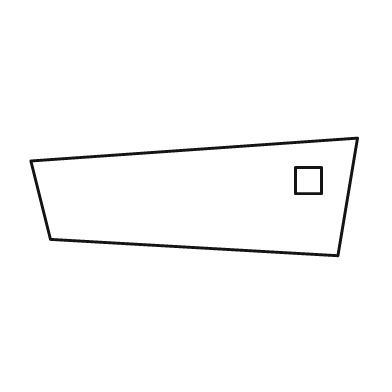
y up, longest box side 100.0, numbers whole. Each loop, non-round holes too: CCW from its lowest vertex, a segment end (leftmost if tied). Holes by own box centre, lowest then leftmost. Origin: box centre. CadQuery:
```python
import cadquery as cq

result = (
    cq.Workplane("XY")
    .moveTo(44.0, -18.0)
    .lineTo(50.0, 18.0)
    .lineTo(-50.0, 11.0)
    .lineTo(-44.0, -13.0)
    .close()
    .moveTo(31.0, 1.0)
    .lineTo(39.0, 1.0)
    .lineTo(39.0, 9.0)
    .lineTo(31.0, 9.0)
    .close()
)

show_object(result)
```